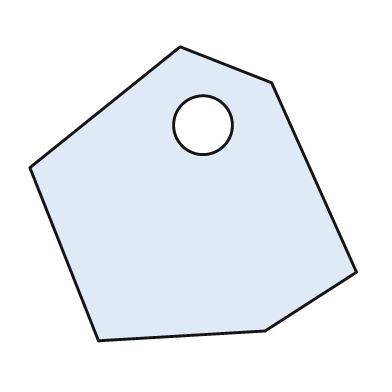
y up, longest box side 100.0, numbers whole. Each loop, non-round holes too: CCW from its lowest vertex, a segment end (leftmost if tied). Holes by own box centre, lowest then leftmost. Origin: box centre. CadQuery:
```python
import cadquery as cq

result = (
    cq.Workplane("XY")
    .moveTo(-29.0, -45.0)
    .lineTo(22.0, -42.0)
    .lineTo(50.0, -24.0)
    .lineTo(24.0, 34.0)
    .lineTo(-4.0, 45.0)
    .lineTo(-50.0, 8.0)
    .close()
    .moveTo(3.0, 21.0)
    .circle(9.0)
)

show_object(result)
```